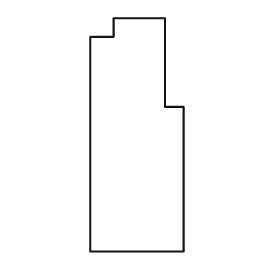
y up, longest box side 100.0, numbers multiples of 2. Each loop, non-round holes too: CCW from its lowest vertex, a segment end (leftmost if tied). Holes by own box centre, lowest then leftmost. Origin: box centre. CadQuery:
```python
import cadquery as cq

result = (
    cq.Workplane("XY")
    .moveTo(-20.0, -50.0)
    .lineTo(20.0, -50.0)
    .lineTo(20.0, 12.0)
    .lineTo(12.0, 12.0)
    .lineTo(12.0, 50.0)
    .lineTo(-10.0, 50.0)
    .lineTo(-10.0, 42.0)
    .lineTo(-20.0, 42.0)
    .close()
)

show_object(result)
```